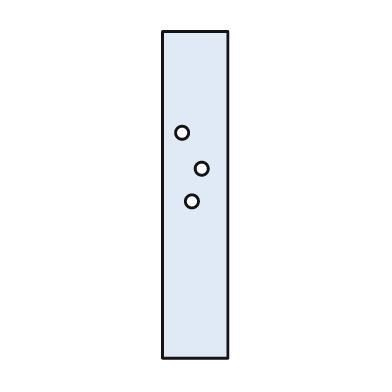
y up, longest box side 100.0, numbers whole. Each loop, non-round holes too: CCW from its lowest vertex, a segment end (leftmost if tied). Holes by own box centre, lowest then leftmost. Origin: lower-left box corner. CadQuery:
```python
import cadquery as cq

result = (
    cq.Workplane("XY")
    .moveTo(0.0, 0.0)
    .lineTo(20.0, 0.0)
    .lineTo(20.0, 100.0)
    .lineTo(0.0, 100.0)
    .close()
    .moveTo(9.0, 48.0)
    .circle(2.0)
    .moveTo(12.0, 58.0)
    .circle(2.0)
    .moveTo(6.0, 69.0)
    .circle(2.0)
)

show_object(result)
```